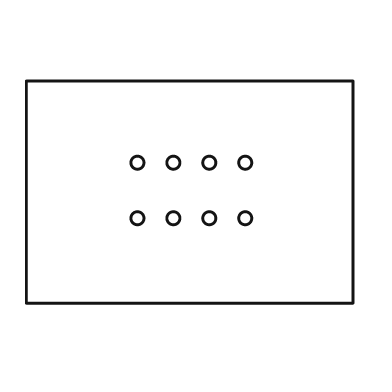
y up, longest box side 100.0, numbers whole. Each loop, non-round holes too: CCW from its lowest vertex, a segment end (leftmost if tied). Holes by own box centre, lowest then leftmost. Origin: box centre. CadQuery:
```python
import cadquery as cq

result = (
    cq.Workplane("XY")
    .moveTo(-50.0, -34.0)
    .lineTo(50.0, -34.0)
    .lineTo(50.0, 34.0)
    .lineTo(-50.0, 34.0)
    .close()
    .moveTo(-16.0, -8.0)
    .circle(2.0)
    .moveTo(-5.0, -8.0)
    .circle(2.0)
    .moveTo(6.0, -8.0)
    .circle(2.0)
    .moveTo(17.0, -8.0)
    .circle(2.0)
    .moveTo(-16.0, 9.0)
    .circle(2.0)
    .moveTo(-5.0, 9.0)
    .circle(2.0)
    .moveTo(6.0, 9.0)
    .circle(2.0)
    .moveTo(17.0, 9.0)
    .circle(2.0)
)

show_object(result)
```